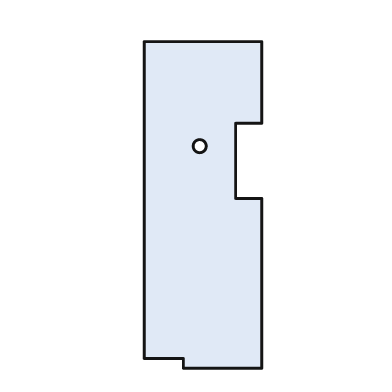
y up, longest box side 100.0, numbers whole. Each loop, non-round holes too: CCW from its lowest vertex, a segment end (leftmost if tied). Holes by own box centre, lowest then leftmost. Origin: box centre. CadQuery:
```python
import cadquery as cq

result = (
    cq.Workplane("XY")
    .moveTo(-6.0, -50.0)
    .lineTo(18.0, -50.0)
    .lineTo(18.0, 2.0)
    .lineTo(10.0, 2.0)
    .lineTo(10.0, 25.0)
    .lineTo(18.0, 25.0)
    .lineTo(18.0, 50.0)
    .lineTo(-18.0, 50.0)
    .lineTo(-18.0, -47.0)
    .lineTo(-6.0, -47.0)
    .close()
    .moveTo(-1.0, 18.0)
    .circle(2.0)
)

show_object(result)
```